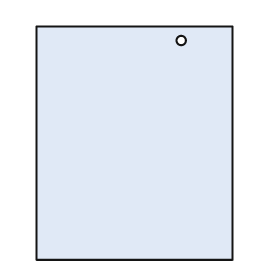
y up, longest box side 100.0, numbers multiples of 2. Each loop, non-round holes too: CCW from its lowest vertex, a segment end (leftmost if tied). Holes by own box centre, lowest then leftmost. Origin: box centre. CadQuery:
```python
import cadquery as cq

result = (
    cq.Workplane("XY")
    .moveTo(-42.0, -50.0)
    .lineTo(42.0, -50.0)
    .lineTo(42.0, 50.0)
    .lineTo(-42.0, 50.0)
    .close()
    .moveTo(20.0, 44.0)
    .circle(2.0)
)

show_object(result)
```